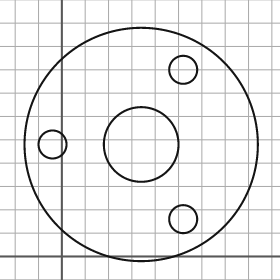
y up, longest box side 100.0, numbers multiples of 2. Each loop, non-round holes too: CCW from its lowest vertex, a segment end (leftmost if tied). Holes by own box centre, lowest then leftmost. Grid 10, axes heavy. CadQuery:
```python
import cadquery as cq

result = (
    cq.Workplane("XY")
    .moveTo(34.0, 48.0)
    .circle(50.0)
    .moveTo(52.0, 16.0)
    .circle(6.0)
    .moveTo(-4.0, 48.0)
    .circle(6.0)
    .moveTo(34.0, 48.0)
    .circle(16.0)
    .moveTo(52.0, 80.0)
    .circle(6.0)
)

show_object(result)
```